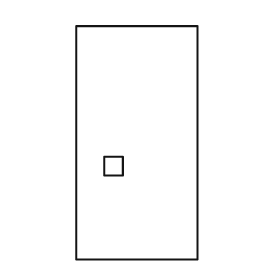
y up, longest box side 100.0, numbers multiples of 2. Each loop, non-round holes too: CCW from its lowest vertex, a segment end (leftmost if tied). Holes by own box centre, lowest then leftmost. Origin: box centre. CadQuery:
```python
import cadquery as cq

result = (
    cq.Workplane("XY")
    .moveTo(-26.0, -50.0)
    .lineTo(26.0, -50.0)
    .lineTo(26.0, 50.0)
    .lineTo(-26.0, 50.0)
    .close()
    .moveTo(-14.0, -14.0)
    .lineTo(-6.0, -14.0)
    .lineTo(-6.0, -6.0)
    .lineTo(-14.0, -6.0)
    .close()
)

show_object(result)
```